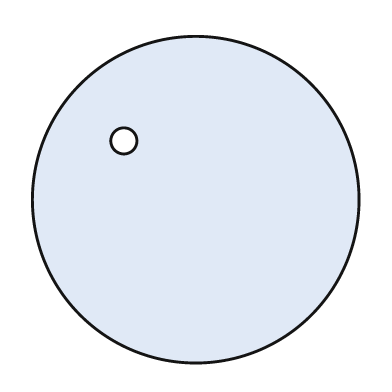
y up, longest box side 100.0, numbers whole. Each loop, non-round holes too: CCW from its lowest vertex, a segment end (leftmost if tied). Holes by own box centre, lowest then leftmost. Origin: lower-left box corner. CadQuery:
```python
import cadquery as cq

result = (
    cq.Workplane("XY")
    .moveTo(50.0, 50.0)
    .circle(50.0)
    .moveTo(28.0, 68.0)
    .circle(4.0)
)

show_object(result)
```